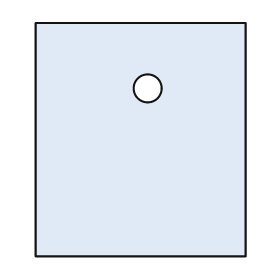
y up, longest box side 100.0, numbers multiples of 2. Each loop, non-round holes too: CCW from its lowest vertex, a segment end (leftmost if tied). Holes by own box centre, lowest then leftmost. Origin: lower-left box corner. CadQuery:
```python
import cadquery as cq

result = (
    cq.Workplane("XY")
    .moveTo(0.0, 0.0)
    .lineTo(90.0, 0.0)
    .lineTo(90.0, 100.0)
    .lineTo(0.0, 100.0)
    .close()
    .moveTo(48.0, 72.0)
    .circle(6.0)
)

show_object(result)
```